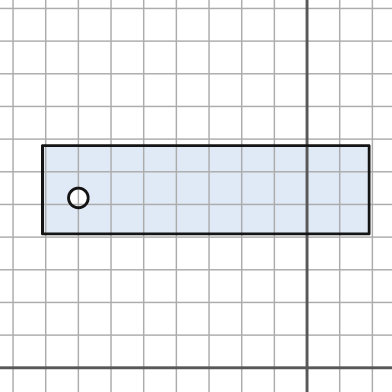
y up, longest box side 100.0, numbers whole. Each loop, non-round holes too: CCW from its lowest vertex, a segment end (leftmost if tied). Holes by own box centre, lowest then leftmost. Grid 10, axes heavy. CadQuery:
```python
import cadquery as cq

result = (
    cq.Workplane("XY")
    .moveTo(-81.0, 41.0)
    .lineTo(19.0, 41.0)
    .lineTo(19.0, 68.0)
    .lineTo(-81.0, 68.0)
    .close()
    .moveTo(-70.0, 52.0)
    .circle(3.0)
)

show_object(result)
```